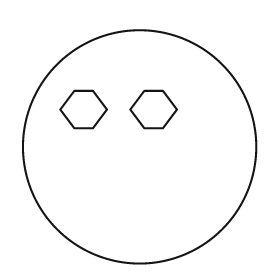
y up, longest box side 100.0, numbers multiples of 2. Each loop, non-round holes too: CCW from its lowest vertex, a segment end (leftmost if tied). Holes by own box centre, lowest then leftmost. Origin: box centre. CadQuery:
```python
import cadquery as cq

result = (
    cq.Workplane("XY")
    .moveTo(0.0, 0.0)
    .circle(50.0)
    .moveTo(-28.0, 8.0)
    .lineTo(-20.0, 8.0)
    .lineTo(-14.0, 16.0)
    .lineTo(-20.0, 24.0)
    .lineTo(-28.0, 24.0)
    .lineTo(-34.0, 16.0)
    .close()
    .moveTo(2.0, 8.0)
    .lineTo(10.0, 8.0)
    .lineTo(16.0, 16.0)
    .lineTo(10.0, 24.0)
    .lineTo(2.0, 24.0)
    .lineTo(-4.0, 16.0)
    .close()
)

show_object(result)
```